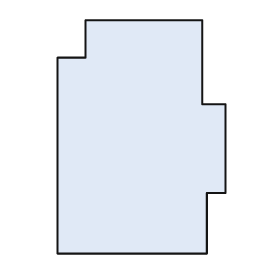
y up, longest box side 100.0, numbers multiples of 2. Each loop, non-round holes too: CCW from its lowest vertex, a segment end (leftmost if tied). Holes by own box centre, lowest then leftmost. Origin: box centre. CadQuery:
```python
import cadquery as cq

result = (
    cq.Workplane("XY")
    .moveTo(-36.0, -50.0)
    .lineTo(28.0, -50.0)
    .lineTo(28.0, -24.0)
    .lineTo(36.0, -24.0)
    .lineTo(36.0, 14.0)
    .lineTo(26.0, 14.0)
    .lineTo(26.0, 50.0)
    .lineTo(-24.0, 50.0)
    .lineTo(-24.0, 34.0)
    .lineTo(-36.0, 34.0)
    .close()
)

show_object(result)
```